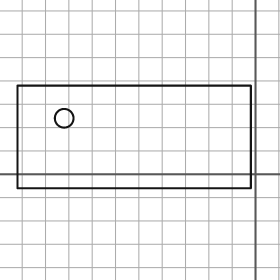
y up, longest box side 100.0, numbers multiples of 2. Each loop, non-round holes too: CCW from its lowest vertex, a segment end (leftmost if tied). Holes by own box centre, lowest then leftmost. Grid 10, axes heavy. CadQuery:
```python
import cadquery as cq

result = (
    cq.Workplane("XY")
    .moveTo(-102.0, -6.0)
    .lineTo(-2.0, -6.0)
    .lineTo(-2.0, 38.0)
    .lineTo(-102.0, 38.0)
    .close()
    .moveTo(-82.0, 24.0)
    .circle(4.0)
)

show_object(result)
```